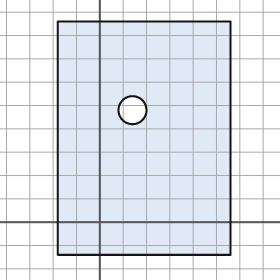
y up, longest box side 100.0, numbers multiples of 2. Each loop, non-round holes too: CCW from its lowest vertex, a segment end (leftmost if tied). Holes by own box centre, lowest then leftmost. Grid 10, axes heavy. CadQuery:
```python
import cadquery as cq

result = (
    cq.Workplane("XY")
    .moveTo(-18.0, -14.0)
    .lineTo(56.0, -14.0)
    .lineTo(56.0, 86.0)
    .lineTo(-18.0, 86.0)
    .close()
    .moveTo(14.0, 48.0)
    .circle(6.0)
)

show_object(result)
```